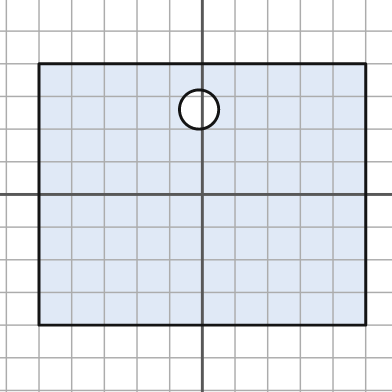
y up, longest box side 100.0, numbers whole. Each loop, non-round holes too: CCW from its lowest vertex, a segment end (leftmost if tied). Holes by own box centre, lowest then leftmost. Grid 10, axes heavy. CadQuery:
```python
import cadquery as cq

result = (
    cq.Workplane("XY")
    .moveTo(-50.0, -40.0)
    .lineTo(50.0, -40.0)
    .lineTo(50.0, 40.0)
    .lineTo(-50.0, 40.0)
    .close()
    .moveTo(-1.0, 26.0)
    .circle(6.0)
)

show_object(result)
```